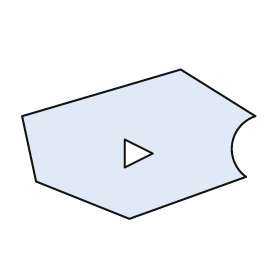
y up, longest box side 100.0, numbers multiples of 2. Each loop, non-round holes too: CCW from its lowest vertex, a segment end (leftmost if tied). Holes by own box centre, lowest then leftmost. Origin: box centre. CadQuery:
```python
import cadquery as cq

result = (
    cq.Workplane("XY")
    .moveTo(-4.0, -32.0)
    .lineTo(46.0, -14.0)
    .threePointArc((40.0, 0.0), (50.0, 12.0))
    .lineTo(18.0, 32.0)
    .lineTo(-50.0, 12.0)
    .lineTo(-44.0, -16.0)
    .close()
    .moveTo(-6.0, -10.0)
    .lineTo(6.0, -4.0)
    .lineTo(-6.0, 2.0)
    .close()
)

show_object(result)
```